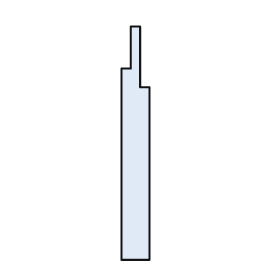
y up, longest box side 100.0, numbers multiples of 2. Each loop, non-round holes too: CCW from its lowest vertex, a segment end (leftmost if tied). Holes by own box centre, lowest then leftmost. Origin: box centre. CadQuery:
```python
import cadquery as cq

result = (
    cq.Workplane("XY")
    .moveTo(-6.0, -50.0)
    .lineTo(6.0, -50.0)
    .lineTo(6.0, 24.0)
    .lineTo(2.0, 24.0)
    .lineTo(2.0, 50.0)
    .lineTo(-2.0, 50.0)
    .lineTo(-2.0, 32.0)
    .lineTo(-6.0, 32.0)
    .close()
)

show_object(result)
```